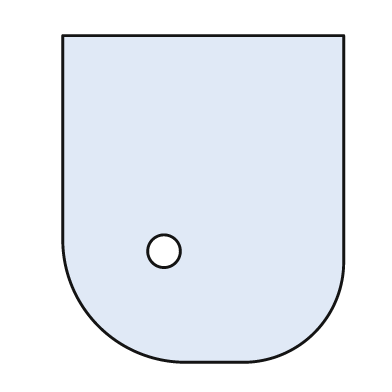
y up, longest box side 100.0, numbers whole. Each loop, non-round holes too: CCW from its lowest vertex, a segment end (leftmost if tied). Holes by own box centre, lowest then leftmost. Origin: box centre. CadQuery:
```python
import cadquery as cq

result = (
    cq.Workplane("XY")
    .moveTo(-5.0, -50.0)
    .lineTo(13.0, -50.0)
    .threePointArc((34.0, -41.0), (43.0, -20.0))
    .lineTo(43.0, 50.0)
    .lineTo(-43.0, 50.0)
    .lineTo(-43.0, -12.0)
    .threePointArc((-32.0, -39.0), (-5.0, -50.0))
    .close()
    .moveTo(-12.0, -16.0)
    .circle(5.0)
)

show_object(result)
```